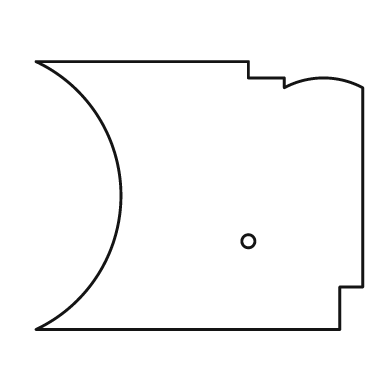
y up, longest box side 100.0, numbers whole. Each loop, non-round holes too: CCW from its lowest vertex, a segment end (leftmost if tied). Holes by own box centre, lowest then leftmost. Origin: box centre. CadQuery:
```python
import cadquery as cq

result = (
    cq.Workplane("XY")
    .moveTo(-50.0, -41.0)
    .lineTo(43.0, -41.0)
    .lineTo(43.0, -28.0)
    .lineTo(50.0, -28.0)
    .lineTo(50.0, 33.0)
    .threePointArc((38.0, 36.0), (26.0, 33.0))
    .lineTo(26.0, 36.0)
    .lineTo(15.0, 36.0)
    .lineTo(15.0, 41.0)
    .lineTo(-50.0, 41.0)
    .threePointArc((-24.0, 0.0), (-50.0, -41.0))
    .close()
    .moveTo(15.0, -14.0)
    .circle(2.0)
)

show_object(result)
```